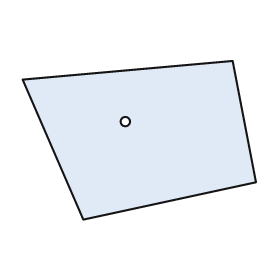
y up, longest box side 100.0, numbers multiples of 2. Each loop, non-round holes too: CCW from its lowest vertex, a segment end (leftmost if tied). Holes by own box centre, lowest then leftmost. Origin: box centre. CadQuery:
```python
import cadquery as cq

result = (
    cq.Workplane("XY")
    .moveTo(-24.0, -34.0)
    .lineTo(50.0, -18.0)
    .lineTo(40.0, 34.0)
    .lineTo(-50.0, 26.0)
    .close()
    .moveTo(-6.0, 8.0)
    .circle(2.0)
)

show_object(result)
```